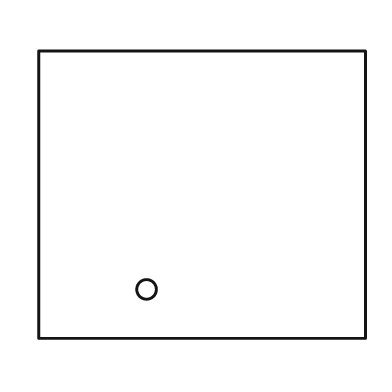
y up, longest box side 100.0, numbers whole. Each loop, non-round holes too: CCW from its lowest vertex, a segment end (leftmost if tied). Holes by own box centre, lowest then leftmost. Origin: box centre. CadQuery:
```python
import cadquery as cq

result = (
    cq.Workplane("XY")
    .moveTo(-50.0, -44.0)
    .lineTo(50.0, -44.0)
    .lineTo(50.0, 44.0)
    .lineTo(-50.0, 44.0)
    .close()
    .moveTo(-17.0, -29.0)
    .circle(3.0)
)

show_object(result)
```